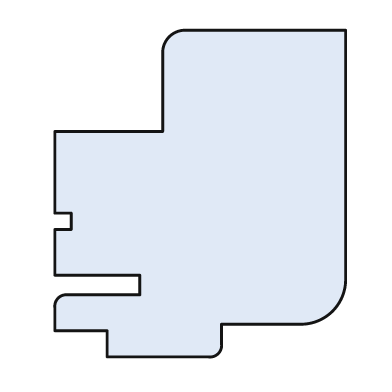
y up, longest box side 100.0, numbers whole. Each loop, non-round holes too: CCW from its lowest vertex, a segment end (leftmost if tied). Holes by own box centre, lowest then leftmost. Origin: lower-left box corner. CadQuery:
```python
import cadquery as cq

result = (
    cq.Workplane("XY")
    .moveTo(16.0, 0.0)
    .lineTo(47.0, 0.0)
    .threePointArc((50.0, 1.0), (51.0, 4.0))
    .lineTo(51.0, 10.0)
    .lineTo(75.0, 10.0)
    .threePointArc((85.0, 14.0), (89.0, 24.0))
    .lineTo(89.0, 100.0)
    .lineTo(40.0, 100.0)
    .threePointArc((35.0, 98.0), (33.0, 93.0))
    .lineTo(33.0, 69.0)
    .lineTo(0.0, 69.0)
    .lineTo(0.0, 44.0)
    .lineTo(5.0, 44.0)
    .lineTo(5.0, 39.0)
    .lineTo(0.0, 39.0)
    .lineTo(0.0, 25.0)
    .lineTo(26.0, 25.0)
    .lineTo(26.0, 19.0)
    .lineTo(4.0, 19.0)
    .threePointArc((1.0, 18.0), (0.0, 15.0))
    .lineTo(0.0, 8.0)
    .lineTo(16.0, 8.0)
    .close()
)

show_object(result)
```